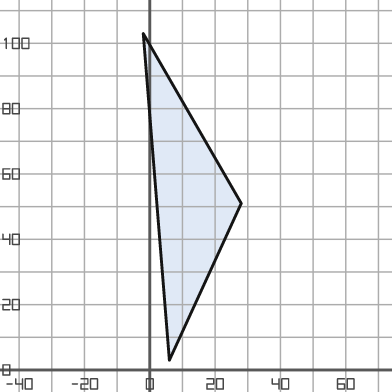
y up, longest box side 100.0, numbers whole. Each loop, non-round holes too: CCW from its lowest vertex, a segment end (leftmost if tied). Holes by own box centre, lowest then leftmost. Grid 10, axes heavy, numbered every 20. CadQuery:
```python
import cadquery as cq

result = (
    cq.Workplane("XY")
    .moveTo(6.0, 3.0)
    .lineTo(28.0, 51.0)
    .lineTo(-2.0, 103.0)
    .close()
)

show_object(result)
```